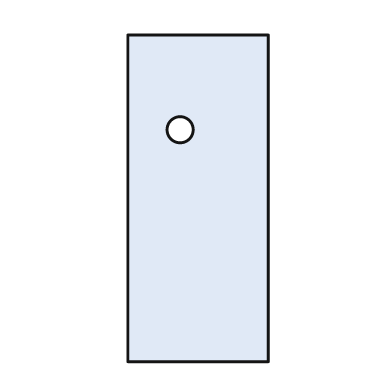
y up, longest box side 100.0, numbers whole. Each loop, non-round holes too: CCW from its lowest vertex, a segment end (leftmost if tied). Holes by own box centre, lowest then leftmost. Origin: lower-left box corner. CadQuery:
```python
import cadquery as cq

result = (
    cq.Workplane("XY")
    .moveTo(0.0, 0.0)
    .lineTo(43.0, 0.0)
    .lineTo(43.0, 100.0)
    .lineTo(0.0, 100.0)
    .close()
    .moveTo(16.0, 71.0)
    .circle(4.0)
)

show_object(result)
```